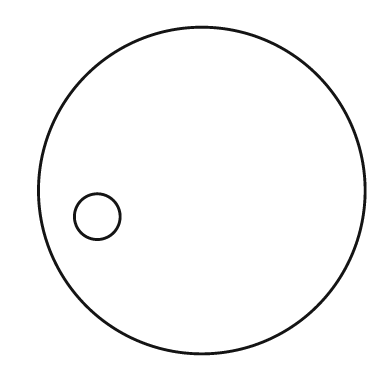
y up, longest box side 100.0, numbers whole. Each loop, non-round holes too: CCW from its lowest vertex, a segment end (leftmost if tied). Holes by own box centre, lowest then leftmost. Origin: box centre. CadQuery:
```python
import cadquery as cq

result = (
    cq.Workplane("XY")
    .moveTo(0.0, 0.0)
    .circle(50.0)
    .moveTo(-32.0, -8.0)
    .circle(7.0)
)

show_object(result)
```